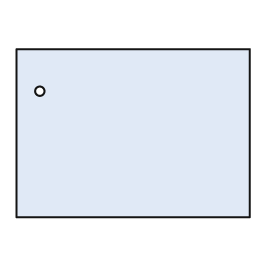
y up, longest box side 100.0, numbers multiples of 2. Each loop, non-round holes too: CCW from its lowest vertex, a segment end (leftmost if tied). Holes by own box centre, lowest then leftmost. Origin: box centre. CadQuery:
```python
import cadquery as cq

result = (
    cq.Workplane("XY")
    .moveTo(-50.0, -36.0)
    .lineTo(50.0, -36.0)
    .lineTo(50.0, 36.0)
    .lineTo(-50.0, 36.0)
    .close()
    .moveTo(-40.0, 18.0)
    .circle(2.0)
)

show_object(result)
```